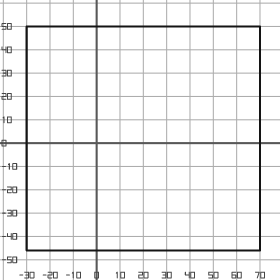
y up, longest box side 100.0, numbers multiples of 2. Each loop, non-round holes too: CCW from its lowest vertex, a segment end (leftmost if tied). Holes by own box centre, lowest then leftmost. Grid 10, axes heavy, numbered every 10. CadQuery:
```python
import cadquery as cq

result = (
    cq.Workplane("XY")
    .moveTo(-30.0, -46.0)
    .lineTo(70.0, -46.0)
    .lineTo(70.0, 50.0)
    .lineTo(-30.0, 50.0)
    .close()
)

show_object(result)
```